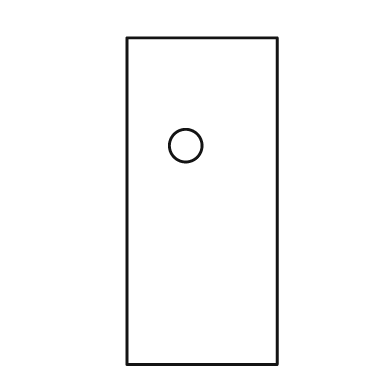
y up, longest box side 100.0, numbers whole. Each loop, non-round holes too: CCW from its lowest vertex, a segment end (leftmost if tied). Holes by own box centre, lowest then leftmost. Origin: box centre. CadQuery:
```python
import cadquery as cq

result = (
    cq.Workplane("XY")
    .moveTo(-23.0, -50.0)
    .lineTo(23.0, -50.0)
    .lineTo(23.0, 50.0)
    .lineTo(-23.0, 50.0)
    .close()
    .moveTo(-5.0, 17.0)
    .circle(5.0)
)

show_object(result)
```